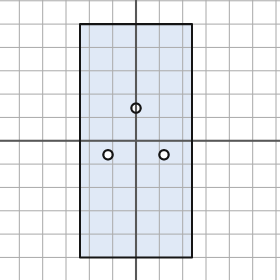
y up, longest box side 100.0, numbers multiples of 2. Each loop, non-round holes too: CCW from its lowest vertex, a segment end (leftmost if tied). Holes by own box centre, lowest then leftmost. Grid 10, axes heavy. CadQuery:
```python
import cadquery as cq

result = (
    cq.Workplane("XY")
    .moveTo(-24.0, -50.0)
    .lineTo(24.0, -50.0)
    .lineTo(24.0, 50.0)
    .lineTo(-24.0, 50.0)
    .close()
    .moveTo(-12.0, -6.0)
    .circle(2.0)
    .moveTo(12.0, -6.0)
    .circle(2.0)
    .moveTo(0.0, 14.0)
    .circle(2.0)
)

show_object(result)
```